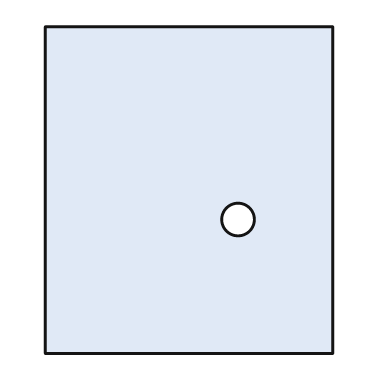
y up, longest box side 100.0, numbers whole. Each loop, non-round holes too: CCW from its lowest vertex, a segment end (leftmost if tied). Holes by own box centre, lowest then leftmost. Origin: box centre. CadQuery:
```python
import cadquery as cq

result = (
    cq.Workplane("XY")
    .moveTo(-44.0, -50.0)
    .lineTo(44.0, -50.0)
    .lineTo(44.0, 50.0)
    .lineTo(-44.0, 50.0)
    .close()
    .moveTo(15.0, -9.0)
    .circle(5.0)
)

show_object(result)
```